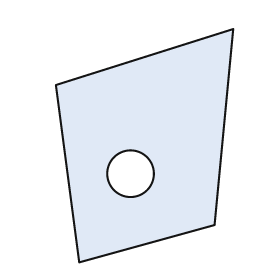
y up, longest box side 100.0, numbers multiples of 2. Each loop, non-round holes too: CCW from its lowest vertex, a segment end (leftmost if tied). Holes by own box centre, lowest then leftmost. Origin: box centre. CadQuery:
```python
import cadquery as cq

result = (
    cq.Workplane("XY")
    .moveTo(-28.0, -50.0)
    .lineTo(30.0, -34.0)
    .lineTo(38.0, 50.0)
    .lineTo(-38.0, 26.0)
    .close()
    .moveTo(-6.0, -12.0)
    .circle(10.0)
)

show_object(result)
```